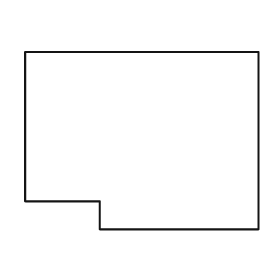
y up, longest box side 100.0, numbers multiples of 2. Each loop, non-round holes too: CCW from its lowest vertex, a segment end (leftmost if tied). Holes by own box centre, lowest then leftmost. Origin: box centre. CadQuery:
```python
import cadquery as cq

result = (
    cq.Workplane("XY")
    .moveTo(-18.0, -38.0)
    .lineTo(50.0, -38.0)
    .lineTo(50.0, 38.0)
    .lineTo(-50.0, 38.0)
    .lineTo(-50.0, -26.0)
    .lineTo(-18.0, -26.0)
    .close()
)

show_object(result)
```